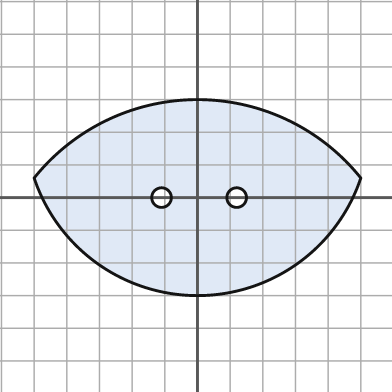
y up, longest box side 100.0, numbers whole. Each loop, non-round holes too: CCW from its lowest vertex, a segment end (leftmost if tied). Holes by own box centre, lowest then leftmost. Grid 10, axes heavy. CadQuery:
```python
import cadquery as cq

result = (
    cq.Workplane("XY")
    .moveTo(-50.0, 6.0)
    .threePointArc((0.0, -30.0), (50.0, 6.0))
    .threePointArc((0.0, 30.0), (-50.0, 6.0))
    .close()
    .moveTo(-11.0, 0.0)
    .circle(3.0)
    .moveTo(12.0, 0.0)
    .circle(3.0)
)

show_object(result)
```